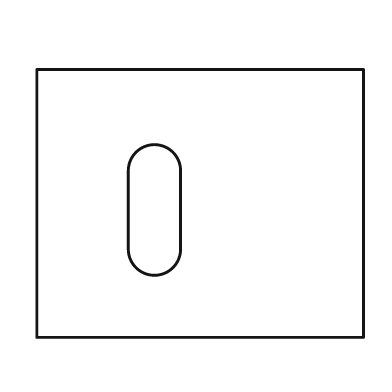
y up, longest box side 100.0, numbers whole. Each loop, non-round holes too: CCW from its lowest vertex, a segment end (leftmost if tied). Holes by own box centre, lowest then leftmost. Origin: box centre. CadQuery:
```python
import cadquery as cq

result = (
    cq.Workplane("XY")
    .moveTo(-50.0, -41.0)
    .lineTo(50.0, -41.0)
    .lineTo(50.0, 41.0)
    .lineTo(-50.0, 41.0)
    .close()
    .moveTo(-22.0, -14.0)
    .threePointArc((-14.0, -22.0), (-6.0, -14.0))
    .lineTo(-6.0, 10.0)
    .threePointArc((-14.0, 18.0), (-22.0, 10.0))
    .close()
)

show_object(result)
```